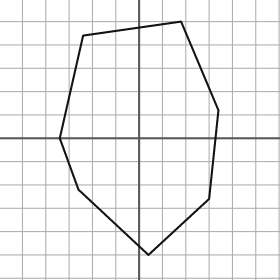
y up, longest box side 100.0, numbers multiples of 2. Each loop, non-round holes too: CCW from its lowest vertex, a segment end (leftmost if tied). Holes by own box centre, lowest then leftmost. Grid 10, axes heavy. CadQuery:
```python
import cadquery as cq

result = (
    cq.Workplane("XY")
    .moveTo(4.0, -50.0)
    .lineTo(30.0, -26.0)
    .lineTo(34.0, 12.0)
    .lineTo(18.0, 50.0)
    .lineTo(-24.0, 44.0)
    .lineTo(-34.0, 0.0)
    .lineTo(-26.0, -22.0)
    .close()
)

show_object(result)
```